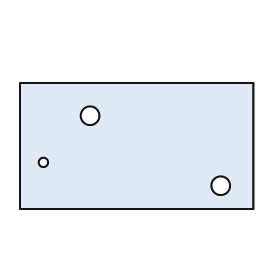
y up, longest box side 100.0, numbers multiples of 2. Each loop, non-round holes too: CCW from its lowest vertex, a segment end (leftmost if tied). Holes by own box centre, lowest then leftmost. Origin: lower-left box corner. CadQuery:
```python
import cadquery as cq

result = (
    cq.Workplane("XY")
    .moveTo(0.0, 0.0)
    .lineTo(100.0, 0.0)
    .lineTo(100.0, 54.0)
    .lineTo(0.0, 54.0)
    .close()
    .moveTo(86.0, 10.0)
    .circle(4.0)
    .moveTo(10.0, 20.0)
    .circle(2.0)
    .moveTo(30.0, 40.0)
    .circle(4.0)
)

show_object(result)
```